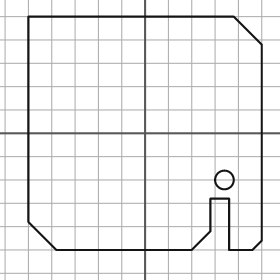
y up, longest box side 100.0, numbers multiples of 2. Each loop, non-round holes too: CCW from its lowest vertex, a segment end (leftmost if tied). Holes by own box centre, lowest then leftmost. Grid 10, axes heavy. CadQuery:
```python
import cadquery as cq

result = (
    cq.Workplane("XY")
    .moveTo(-38.0, -50.0)
    .lineTo(20.0, -50.0)
    .lineTo(28.0, -42.0)
    .lineTo(28.0, -28.0)
    .lineTo(36.0, -28.0)
    .lineTo(36.0, -50.0)
    .lineTo(46.0, -50.0)
    .lineTo(50.0, -46.0)
    .lineTo(50.0, 38.0)
    .lineTo(38.0, 50.0)
    .lineTo(-50.0, 50.0)
    .lineTo(-50.0, -38.0)
    .close()
    .moveTo(34.0, -20.0)
    .circle(4.0)
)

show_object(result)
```